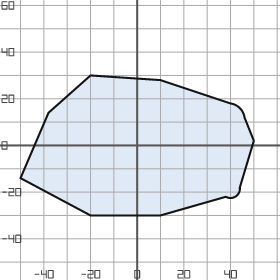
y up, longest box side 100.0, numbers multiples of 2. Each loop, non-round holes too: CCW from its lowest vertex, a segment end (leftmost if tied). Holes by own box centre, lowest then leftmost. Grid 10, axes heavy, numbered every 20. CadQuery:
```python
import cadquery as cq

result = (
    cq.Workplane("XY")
    .moveTo(-20.0, -30.0)
    .lineTo(10.0, -30.0)
    .lineTo(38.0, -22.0)
    .threePointArc((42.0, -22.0), (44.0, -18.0))
    .lineTo(50.0, 2.0)
    .lineTo(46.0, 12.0)
    .threePointArc((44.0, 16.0), (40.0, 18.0))
    .lineTo(10.0, 28.0)
    .lineTo(-20.0, 30.0)
    .lineTo(-38.0, 14.0)
    .lineTo(-50.0, -14.0)
    .close()
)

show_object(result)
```